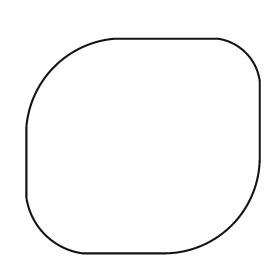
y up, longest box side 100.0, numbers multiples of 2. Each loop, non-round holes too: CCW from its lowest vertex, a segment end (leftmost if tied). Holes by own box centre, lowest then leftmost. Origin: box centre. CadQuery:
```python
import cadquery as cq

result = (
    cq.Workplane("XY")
    .moveTo(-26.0, -46.0)
    .lineTo(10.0, -46.0)
    .threePointArc((38.0, -34.0), (50.0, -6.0))
    .lineTo(50.0, 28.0)
    .threePointArc((44.0, 40.0), (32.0, 46.0))
    .lineTo(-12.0, 46.0)
    .threePointArc((-38.0, 34.0), (-50.0, 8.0))
    .lineTo(-50.0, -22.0)
    .threePointArc((-42.0, -38.0), (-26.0, -46.0))
    .close()
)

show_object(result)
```